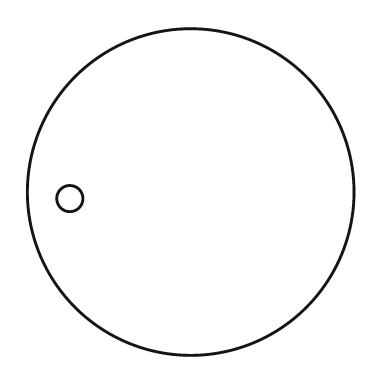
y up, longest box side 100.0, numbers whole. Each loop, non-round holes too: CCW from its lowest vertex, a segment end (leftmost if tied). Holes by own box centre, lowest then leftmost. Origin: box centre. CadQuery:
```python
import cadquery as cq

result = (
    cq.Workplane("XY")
    .moveTo(0.0, 0.0)
    .circle(50.0)
    .moveTo(-37.0, -2.0)
    .circle(4.0)
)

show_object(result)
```